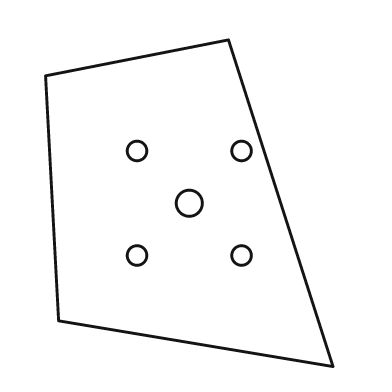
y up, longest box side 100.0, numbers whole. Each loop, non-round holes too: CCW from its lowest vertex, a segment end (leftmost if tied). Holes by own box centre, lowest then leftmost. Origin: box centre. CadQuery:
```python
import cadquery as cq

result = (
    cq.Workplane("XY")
    .moveTo(44.0, -50.0)
    .lineTo(12.0, 50.0)
    .lineTo(-44.0, 39.0)
    .lineTo(-40.0, -36.0)
    .close()
    .moveTo(-16.0, -16.0)
    .circle(3.0)
    .moveTo(16.0, -16.0)
    .circle(3.0)
    .moveTo(0.0, 0.0)
    .circle(4.0)
    .moveTo(-16.0, 16.0)
    .circle(3.0)
    .moveTo(16.0, 16.0)
    .circle(3.0)
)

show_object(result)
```